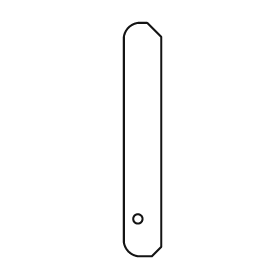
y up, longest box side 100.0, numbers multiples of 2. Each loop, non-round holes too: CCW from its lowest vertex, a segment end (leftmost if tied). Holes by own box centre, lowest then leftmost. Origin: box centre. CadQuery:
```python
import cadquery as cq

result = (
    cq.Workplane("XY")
    .moveTo(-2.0, -50.0)
    .lineTo(4.0, -50.0)
    .lineTo(8.0, -46.0)
    .lineTo(8.0, 44.0)
    .lineTo(2.0, 50.0)
    .lineTo(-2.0, 50.0)
    .threePointArc((-6.0, 48.0), (-8.0, 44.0))
    .lineTo(-8.0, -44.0)
    .threePointArc((-6.0, -48.0), (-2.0, -50.0))
    .close()
    .moveTo(-2.0, -34.0)
    .circle(2.0)
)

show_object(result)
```